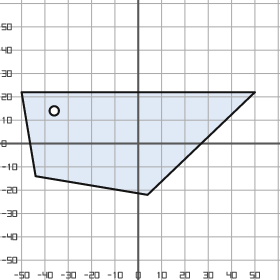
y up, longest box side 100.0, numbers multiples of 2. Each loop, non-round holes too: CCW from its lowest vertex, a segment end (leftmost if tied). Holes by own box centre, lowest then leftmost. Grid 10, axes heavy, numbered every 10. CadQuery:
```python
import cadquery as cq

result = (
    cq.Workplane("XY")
    .moveTo(4.0, -22.0)
    .lineTo(50.0, 22.0)
    .lineTo(-50.0, 22.0)
    .lineTo(-44.0, -14.0)
    .close()
    .moveTo(-36.0, 14.0)
    .circle(2.0)
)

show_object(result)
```